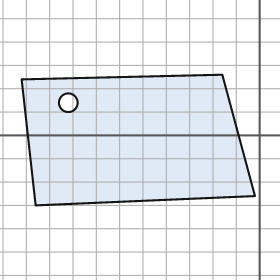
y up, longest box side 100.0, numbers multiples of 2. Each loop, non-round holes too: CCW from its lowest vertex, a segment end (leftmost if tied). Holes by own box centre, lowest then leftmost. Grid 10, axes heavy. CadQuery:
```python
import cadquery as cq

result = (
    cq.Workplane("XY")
    .moveTo(-96.0, -30.0)
    .lineTo(-2.0, -26.0)
    .lineTo(-16.0, 26.0)
    .lineTo(-102.0, 24.0)
    .close()
    .moveTo(-82.0, 14.0)
    .circle(4.0)
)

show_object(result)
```